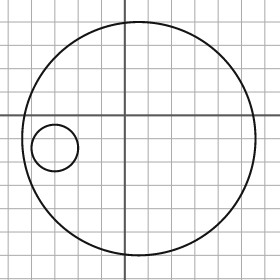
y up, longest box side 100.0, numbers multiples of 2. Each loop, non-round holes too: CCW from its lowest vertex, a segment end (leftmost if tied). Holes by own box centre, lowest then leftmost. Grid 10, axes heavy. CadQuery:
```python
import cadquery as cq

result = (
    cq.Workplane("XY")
    .moveTo(6.0, -10.0)
    .circle(50.0)
    .moveTo(-30.0, -14.0)
    .circle(10.0)
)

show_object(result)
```